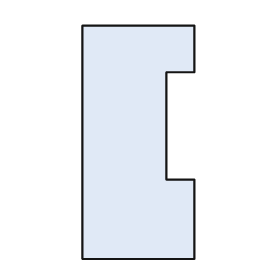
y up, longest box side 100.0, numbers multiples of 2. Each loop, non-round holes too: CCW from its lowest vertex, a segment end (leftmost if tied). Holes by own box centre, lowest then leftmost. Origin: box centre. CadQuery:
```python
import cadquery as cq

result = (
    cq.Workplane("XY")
    .moveTo(-24.0, -50.0)
    .lineTo(24.0, -50.0)
    .lineTo(24.0, -16.0)
    .lineTo(12.0, -16.0)
    .lineTo(12.0, 30.0)
    .lineTo(24.0, 30.0)
    .lineTo(24.0, 50.0)
    .lineTo(-24.0, 50.0)
    .close()
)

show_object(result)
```